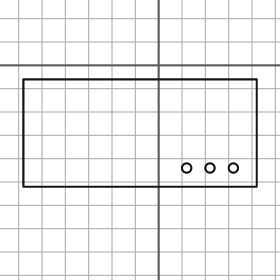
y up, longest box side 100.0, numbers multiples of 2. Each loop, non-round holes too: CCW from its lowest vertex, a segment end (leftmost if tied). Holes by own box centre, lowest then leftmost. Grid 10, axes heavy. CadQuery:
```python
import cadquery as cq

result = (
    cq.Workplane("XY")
    .moveTo(-58.0, -52.0)
    .lineTo(42.0, -52.0)
    .lineTo(42.0, -6.0)
    .lineTo(-58.0, -6.0)
    .close()
    .moveTo(12.0, -44.0)
    .circle(2.0)
    .moveTo(22.0, -44.0)
    .circle(2.0)
    .moveTo(32.0, -44.0)
    .circle(2.0)
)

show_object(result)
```